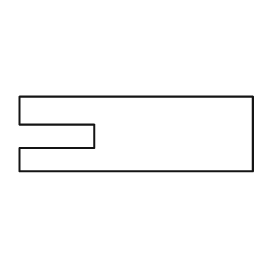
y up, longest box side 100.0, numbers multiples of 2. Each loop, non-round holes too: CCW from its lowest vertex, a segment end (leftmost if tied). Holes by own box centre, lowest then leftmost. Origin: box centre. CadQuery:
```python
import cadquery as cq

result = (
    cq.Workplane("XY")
    .moveTo(-50.0, -16.0)
    .lineTo(50.0, -16.0)
    .lineTo(50.0, 16.0)
    .lineTo(-50.0, 16.0)
    .lineTo(-50.0, 4.0)
    .lineTo(-18.0, 4.0)
    .lineTo(-18.0, -6.0)
    .lineTo(-50.0, -6.0)
    .close()
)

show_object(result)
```